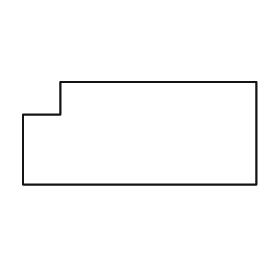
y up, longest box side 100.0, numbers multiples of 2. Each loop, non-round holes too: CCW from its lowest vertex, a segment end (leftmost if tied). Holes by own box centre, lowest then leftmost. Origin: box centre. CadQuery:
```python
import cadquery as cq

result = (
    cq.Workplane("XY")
    .moveTo(-50.0, -22.0)
    .lineTo(50.0, -22.0)
    .lineTo(50.0, 22.0)
    .lineTo(-34.0, 22.0)
    .lineTo(-34.0, 8.0)
    .lineTo(-50.0, 8.0)
    .close()
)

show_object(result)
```